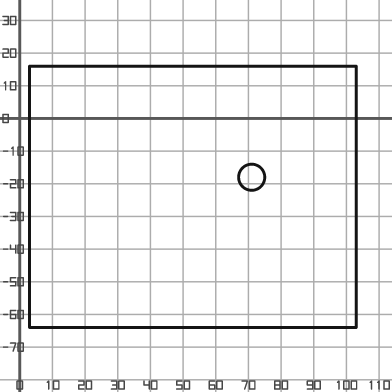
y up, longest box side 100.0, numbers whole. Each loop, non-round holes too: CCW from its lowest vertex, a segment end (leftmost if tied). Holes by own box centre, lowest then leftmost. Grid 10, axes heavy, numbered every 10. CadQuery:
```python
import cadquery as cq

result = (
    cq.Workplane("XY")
    .moveTo(3.0, -64.0)
    .lineTo(103.0, -64.0)
    .lineTo(103.0, 16.0)
    .lineTo(3.0, 16.0)
    .close()
    .moveTo(71.0, -18.0)
    .circle(4.0)
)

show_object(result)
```